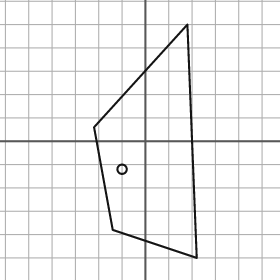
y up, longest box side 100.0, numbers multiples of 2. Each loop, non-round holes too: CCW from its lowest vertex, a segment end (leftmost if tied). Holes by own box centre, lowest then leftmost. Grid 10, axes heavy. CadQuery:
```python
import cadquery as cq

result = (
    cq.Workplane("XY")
    .moveTo(22.0, -50.0)
    .lineTo(18.0, 50.0)
    .lineTo(-22.0, 6.0)
    .lineTo(-14.0, -38.0)
    .close()
    .moveTo(-10.0, -12.0)
    .circle(2.0)
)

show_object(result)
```